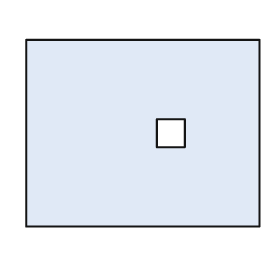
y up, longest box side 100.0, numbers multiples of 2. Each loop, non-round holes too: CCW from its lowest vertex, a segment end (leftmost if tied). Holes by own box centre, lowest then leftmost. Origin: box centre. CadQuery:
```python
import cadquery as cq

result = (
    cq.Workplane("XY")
    .moveTo(-50.0, -40.0)
    .lineTo(50.0, -40.0)
    .lineTo(50.0, 40.0)
    .lineTo(-50.0, 40.0)
    .close()
    .moveTo(6.0, -6.0)
    .lineTo(18.0, -6.0)
    .lineTo(18.0, 6.0)
    .lineTo(6.0, 6.0)
    .close()
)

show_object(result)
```